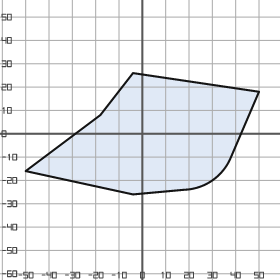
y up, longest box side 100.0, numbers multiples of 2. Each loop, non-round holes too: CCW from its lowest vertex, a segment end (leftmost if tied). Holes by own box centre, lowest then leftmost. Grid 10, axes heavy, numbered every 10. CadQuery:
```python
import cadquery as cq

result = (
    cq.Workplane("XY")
    .moveTo(-4.0, -26.0)
    .lineTo(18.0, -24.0)
    .threePointArc((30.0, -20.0), (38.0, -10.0))
    .lineTo(50.0, 18.0)
    .lineTo(-4.0, 26.0)
    .lineTo(-18.0, 8.0)
    .lineTo(-50.0, -16.0)
    .close()
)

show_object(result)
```